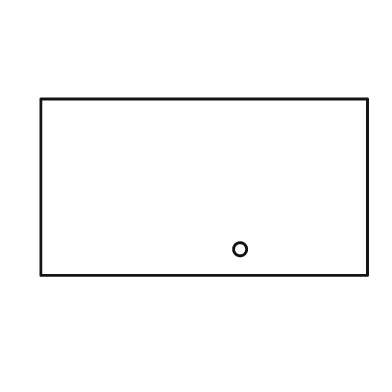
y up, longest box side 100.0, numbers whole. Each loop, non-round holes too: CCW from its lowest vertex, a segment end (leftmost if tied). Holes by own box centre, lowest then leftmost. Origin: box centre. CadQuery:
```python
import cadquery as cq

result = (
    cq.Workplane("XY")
    .moveTo(-50.0, -27.0)
    .lineTo(50.0, -27.0)
    .lineTo(50.0, 27.0)
    .lineTo(-50.0, 27.0)
    .close()
    .moveTo(11.0, -19.0)
    .circle(2.0)
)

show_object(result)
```